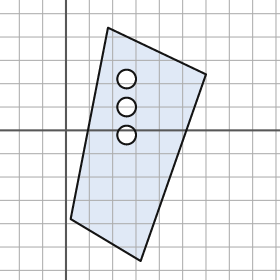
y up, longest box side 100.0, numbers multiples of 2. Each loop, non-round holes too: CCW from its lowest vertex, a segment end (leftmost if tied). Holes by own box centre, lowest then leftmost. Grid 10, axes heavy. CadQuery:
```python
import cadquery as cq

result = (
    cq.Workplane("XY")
    .moveTo(32.0, -56.0)
    .lineTo(60.0, 24.0)
    .lineTo(18.0, 44.0)
    .lineTo(2.0, -38.0)
    .close()
    .moveTo(26.0, -2.0)
    .circle(4.0)
    .moveTo(26.0, 10.0)
    .circle(4.0)
    .moveTo(26.0, 22.0)
    .circle(4.0)
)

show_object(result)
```